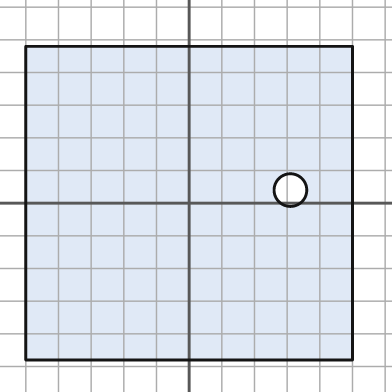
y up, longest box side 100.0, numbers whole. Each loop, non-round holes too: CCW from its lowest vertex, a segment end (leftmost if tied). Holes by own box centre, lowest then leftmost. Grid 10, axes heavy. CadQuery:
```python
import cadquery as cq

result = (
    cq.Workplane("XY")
    .moveTo(-50.0, -48.0)
    .lineTo(50.0, -48.0)
    .lineTo(50.0, 48.0)
    .lineTo(-50.0, 48.0)
    .close()
    .moveTo(31.0, 4.0)
    .circle(5.0)
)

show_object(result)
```